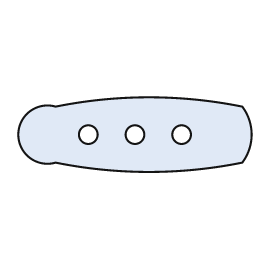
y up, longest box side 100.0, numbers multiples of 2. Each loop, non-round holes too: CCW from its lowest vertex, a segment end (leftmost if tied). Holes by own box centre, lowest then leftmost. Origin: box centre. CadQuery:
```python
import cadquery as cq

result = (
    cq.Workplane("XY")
    .moveTo(-34.0, -12.0)
    .threePointArc((6.0, -16.0), (46.0, -12.0))
    .threePointArc((50.0, 0.0), (46.0, 12.0))
    .threePointArc((6.0, 16.0), (-34.0, 12.0))
    .threePointArc((-50.0, 0.0), (-34.0, -12.0))
    .close()
    .moveTo(-20.0, 0.0)
    .circle(4.0)
    .moveTo(0.0, 0.0)
    .circle(4.0)
    .moveTo(20.0, 0.0)
    .circle(4.0)
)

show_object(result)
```